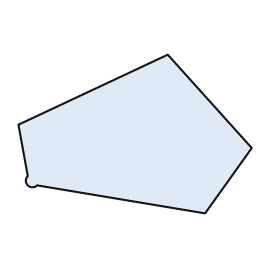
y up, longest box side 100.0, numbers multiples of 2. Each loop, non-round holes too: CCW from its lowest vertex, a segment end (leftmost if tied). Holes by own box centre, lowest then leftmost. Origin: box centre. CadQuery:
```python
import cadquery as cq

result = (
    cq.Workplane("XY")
    .moveTo(30.0, -34.0)
    .lineTo(50.0, -6.0)
    .lineTo(14.0, 34.0)
    .lineTo(-50.0, 4.0)
    .lineTo(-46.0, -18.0)
    .threePointArc((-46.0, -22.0), (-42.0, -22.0))
    .close()
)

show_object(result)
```